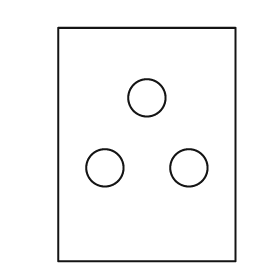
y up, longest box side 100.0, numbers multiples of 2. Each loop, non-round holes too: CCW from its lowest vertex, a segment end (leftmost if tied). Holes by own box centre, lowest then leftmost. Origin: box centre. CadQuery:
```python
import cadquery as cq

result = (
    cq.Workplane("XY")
    .moveTo(-38.0, -50.0)
    .lineTo(38.0, -50.0)
    .lineTo(38.0, 50.0)
    .lineTo(-38.0, 50.0)
    .close()
    .moveTo(-18.0, -10.0)
    .circle(8.0)
    .moveTo(18.0, -10.0)
    .circle(8.0)
    .moveTo(0.0, 20.0)
    .circle(8.0)
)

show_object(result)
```